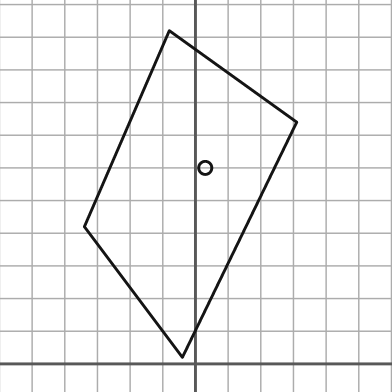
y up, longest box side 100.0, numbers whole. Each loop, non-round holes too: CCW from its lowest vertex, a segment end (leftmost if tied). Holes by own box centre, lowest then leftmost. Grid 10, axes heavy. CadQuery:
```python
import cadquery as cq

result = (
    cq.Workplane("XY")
    .moveTo(-4.0, 2.0)
    .lineTo(31.0, 74.0)
    .lineTo(-8.0, 102.0)
    .lineTo(-34.0, 42.0)
    .close()
    .moveTo(3.0, 60.0)
    .circle(2.0)
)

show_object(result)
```